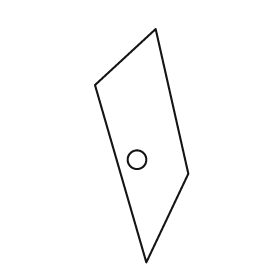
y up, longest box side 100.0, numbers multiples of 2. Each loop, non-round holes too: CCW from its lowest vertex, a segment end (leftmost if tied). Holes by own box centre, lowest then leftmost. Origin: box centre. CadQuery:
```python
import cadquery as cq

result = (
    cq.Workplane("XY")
    .moveTo(2.0, -50.0)
    .lineTo(20.0, -12.0)
    .lineTo(6.0, 50.0)
    .lineTo(-20.0, 26.0)
    .close()
    .moveTo(-2.0, -6.0)
    .circle(4.0)
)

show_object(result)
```